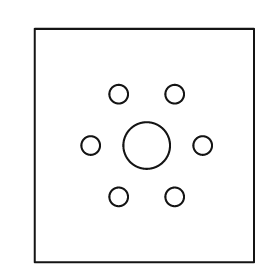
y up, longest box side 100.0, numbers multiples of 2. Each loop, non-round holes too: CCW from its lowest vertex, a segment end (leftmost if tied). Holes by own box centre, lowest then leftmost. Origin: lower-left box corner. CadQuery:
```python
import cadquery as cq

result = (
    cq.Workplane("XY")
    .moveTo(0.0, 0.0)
    .lineTo(94.0, 0.0)
    .lineTo(94.0, 100.0)
    .lineTo(0.0, 100.0)
    .close()
    .moveTo(36.0, 28.0)
    .circle(4.0)
    .moveTo(60.0, 28.0)
    .circle(4.0)
    .moveTo(24.0, 50.0)
    .circle(4.0)
    .moveTo(48.0, 50.0)
    .circle(10.0)
    .moveTo(72.0, 50.0)
    .circle(4.0)
    .moveTo(36.0, 72.0)
    .circle(4.0)
    .moveTo(60.0, 72.0)
    .circle(4.0)
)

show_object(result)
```